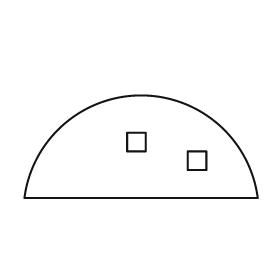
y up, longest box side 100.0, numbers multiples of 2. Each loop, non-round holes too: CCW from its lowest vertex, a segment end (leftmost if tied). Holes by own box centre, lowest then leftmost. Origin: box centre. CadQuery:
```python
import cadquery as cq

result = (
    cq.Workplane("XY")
    .moveTo(-50.0, -22.0)
    .lineTo(50.0, -22.0)
    .threePointArc((0.0, 22.0), (-50.0, -22.0))
    .close()
    .moveTo(20.0, -10.0)
    .lineTo(28.0, -10.0)
    .lineTo(28.0, -2.0)
    .lineTo(20.0, -2.0)
    .close()
    .moveTo(-6.0, -2.0)
    .lineTo(2.0, -2.0)
    .lineTo(2.0, 6.0)
    .lineTo(-6.0, 6.0)
    .close()
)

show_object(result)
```